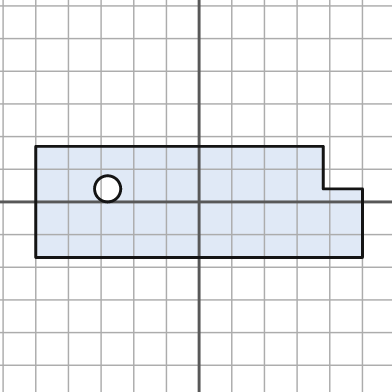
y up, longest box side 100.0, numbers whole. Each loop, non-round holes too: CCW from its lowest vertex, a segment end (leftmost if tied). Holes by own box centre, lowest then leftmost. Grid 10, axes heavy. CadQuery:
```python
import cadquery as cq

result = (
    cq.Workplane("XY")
    .moveTo(-50.0, -17.0)
    .lineTo(50.0, -17.0)
    .lineTo(50.0, 4.0)
    .lineTo(38.0, 4.0)
    .lineTo(38.0, 17.0)
    .lineTo(-50.0, 17.0)
    .close()
    .moveTo(-28.0, 4.0)
    .circle(4.0)
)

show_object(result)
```